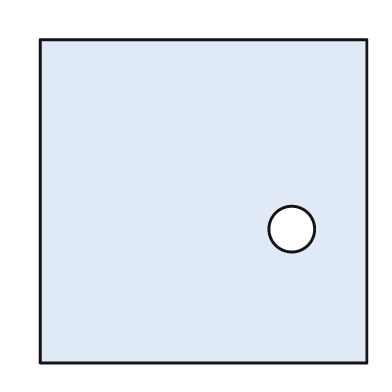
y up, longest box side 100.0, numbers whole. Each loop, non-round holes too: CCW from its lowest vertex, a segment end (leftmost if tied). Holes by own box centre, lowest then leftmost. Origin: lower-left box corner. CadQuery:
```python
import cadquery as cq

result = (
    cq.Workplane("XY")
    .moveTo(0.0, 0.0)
    .lineTo(100.0, 0.0)
    .lineTo(100.0, 99.0)
    .lineTo(0.0, 99.0)
    .close()
    .moveTo(77.0, 41.0)
    .circle(7.0)
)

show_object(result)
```